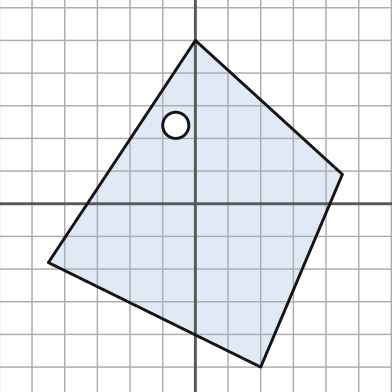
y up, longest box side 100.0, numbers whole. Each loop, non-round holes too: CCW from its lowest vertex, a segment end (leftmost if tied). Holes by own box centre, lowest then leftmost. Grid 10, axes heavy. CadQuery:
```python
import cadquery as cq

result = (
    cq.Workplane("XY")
    .moveTo(20.0, -50.0)
    .lineTo(45.0, 9.0)
    .lineTo(0.0, 50.0)
    .lineTo(-45.0, -18.0)
    .close()
    .moveTo(-6.0, 24.0)
    .circle(4.0)
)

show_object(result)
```